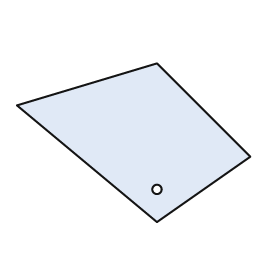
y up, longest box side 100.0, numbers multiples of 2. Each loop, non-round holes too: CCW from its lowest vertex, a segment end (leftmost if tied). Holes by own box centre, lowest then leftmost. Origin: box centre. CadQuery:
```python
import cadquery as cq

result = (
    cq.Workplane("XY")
    .moveTo(10.0, -34.0)
    .lineTo(50.0, -6.0)
    .lineTo(10.0, 34.0)
    .lineTo(-50.0, 16.0)
    .close()
    .moveTo(10.0, -20.0)
    .circle(2.0)
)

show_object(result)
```